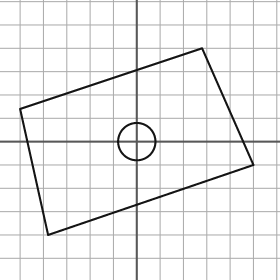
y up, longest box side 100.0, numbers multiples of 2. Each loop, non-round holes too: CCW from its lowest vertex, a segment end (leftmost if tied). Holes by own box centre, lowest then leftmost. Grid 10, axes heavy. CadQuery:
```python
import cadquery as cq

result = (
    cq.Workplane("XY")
    .moveTo(-38.0, -40.0)
    .lineTo(50.0, -10.0)
    .lineTo(28.0, 40.0)
    .lineTo(-50.0, 14.0)
    .close()
    .moveTo(0.0, 0.0)
    .circle(8.0)
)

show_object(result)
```